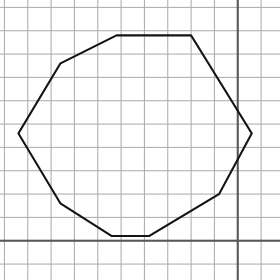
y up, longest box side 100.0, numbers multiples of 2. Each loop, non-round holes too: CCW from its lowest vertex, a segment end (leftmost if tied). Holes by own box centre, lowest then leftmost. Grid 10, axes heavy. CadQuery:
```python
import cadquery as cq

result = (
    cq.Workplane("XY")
    .moveTo(-54.0, 2.0)
    .lineTo(-38.0, 2.0)
    .lineTo(-8.0, 20.0)
    .lineTo(6.0, 46.0)
    .lineTo(-20.0, 88.0)
    .lineTo(-52.0, 88.0)
    .lineTo(-76.0, 76.0)
    .lineTo(-94.0, 46.0)
    .lineTo(-76.0, 16.0)
    .close()
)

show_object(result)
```